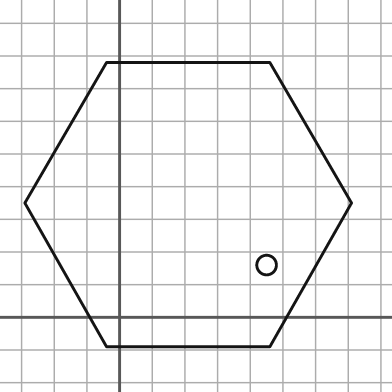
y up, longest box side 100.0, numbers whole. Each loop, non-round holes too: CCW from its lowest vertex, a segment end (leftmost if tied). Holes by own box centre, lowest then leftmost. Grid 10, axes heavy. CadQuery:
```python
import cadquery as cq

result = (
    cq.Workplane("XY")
    .moveTo(-4.0, -9.0)
    .lineTo(46.0, -9.0)
    .lineTo(71.0, 35.0)
    .lineTo(46.0, 78.0)
    .lineTo(-4.0, 78.0)
    .lineTo(-29.0, 35.0)
    .close()
    .moveTo(45.0, 16.0)
    .circle(3.0)
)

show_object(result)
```